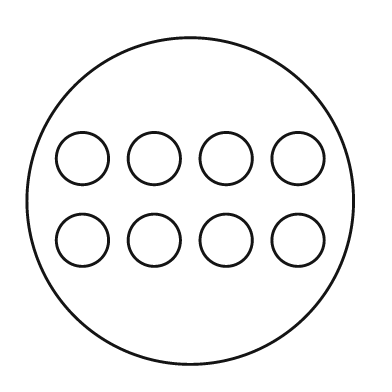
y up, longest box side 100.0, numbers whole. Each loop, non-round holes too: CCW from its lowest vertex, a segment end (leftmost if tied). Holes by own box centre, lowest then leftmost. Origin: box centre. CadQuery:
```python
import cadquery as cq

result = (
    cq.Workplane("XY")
    .moveTo(0.0, 0.0)
    .circle(50.0)
    .moveTo(-33.0, -12.0)
    .circle(8.0)
    .moveTo(-11.0, -12.0)
    .circle(8.0)
    .moveTo(11.0, -12.0)
    .circle(8.0)
    .moveTo(33.0, -12.0)
    .circle(8.0)
    .moveTo(-33.0, 13.0)
    .circle(8.0)
    .moveTo(-11.0, 13.0)
    .circle(8.0)
    .moveTo(11.0, 13.0)
    .circle(8.0)
    .moveTo(33.0, 13.0)
    .circle(8.0)
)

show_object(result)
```